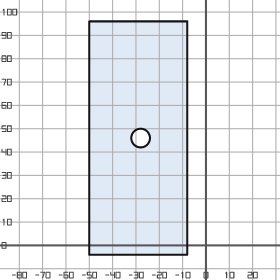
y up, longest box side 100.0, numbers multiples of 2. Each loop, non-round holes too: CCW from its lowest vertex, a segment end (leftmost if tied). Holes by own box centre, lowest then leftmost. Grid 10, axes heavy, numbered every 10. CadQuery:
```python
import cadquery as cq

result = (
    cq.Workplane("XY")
    .moveTo(-50.0, -4.0)
    .lineTo(-8.0, -4.0)
    .lineTo(-8.0, 96.0)
    .lineTo(-50.0, 96.0)
    .close()
    .moveTo(-28.0, 46.0)
    .circle(4.0)
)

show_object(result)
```